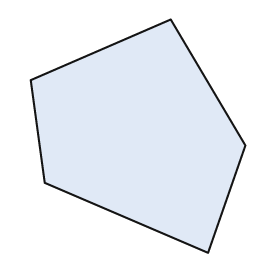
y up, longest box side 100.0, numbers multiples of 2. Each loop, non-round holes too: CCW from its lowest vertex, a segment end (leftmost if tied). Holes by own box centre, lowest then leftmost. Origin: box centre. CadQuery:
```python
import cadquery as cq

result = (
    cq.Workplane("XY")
    .moveTo(30.0, -50.0)
    .lineTo(46.0, -4.0)
    .lineTo(14.0, 50.0)
    .lineTo(-46.0, 24.0)
    .lineTo(-40.0, -20.0)
    .close()
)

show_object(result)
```